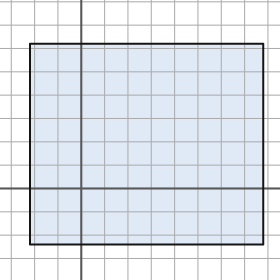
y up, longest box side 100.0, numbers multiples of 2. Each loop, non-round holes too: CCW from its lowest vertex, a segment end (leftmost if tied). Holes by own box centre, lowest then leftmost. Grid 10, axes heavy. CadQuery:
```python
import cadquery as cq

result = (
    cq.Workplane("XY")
    .moveTo(-22.0, -24.0)
    .lineTo(78.0, -24.0)
    .lineTo(78.0, 62.0)
    .lineTo(-22.0, 62.0)
    .close()
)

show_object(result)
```